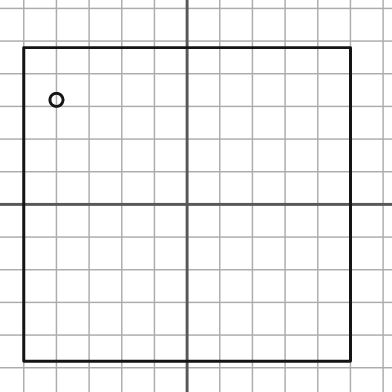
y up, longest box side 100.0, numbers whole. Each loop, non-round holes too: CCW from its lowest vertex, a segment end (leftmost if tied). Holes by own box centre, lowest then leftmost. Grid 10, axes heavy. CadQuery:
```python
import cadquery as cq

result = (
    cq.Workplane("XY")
    .moveTo(-50.0, -48.0)
    .lineTo(50.0, -48.0)
    .lineTo(50.0, 48.0)
    .lineTo(-50.0, 48.0)
    .close()
    .moveTo(-40.0, 32.0)
    .circle(2.0)
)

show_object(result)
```